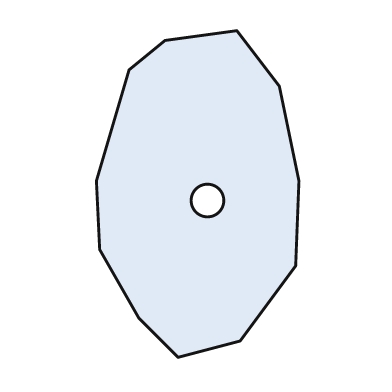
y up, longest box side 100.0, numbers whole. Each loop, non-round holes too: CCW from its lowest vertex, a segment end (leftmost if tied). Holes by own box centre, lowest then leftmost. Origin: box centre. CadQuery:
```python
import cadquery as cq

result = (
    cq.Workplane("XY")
    .moveTo(-6.0, -50.0)
    .lineTo(13.0, -45.0)
    .lineTo(30.0, -22.0)
    .lineTo(31.0, 4.0)
    .lineTo(25.0, 33.0)
    .lineTo(12.0, 50.0)
    .lineTo(-10.0, 47.0)
    .lineTo(-21.0, 38.0)
    .lineTo(-31.0, 4.0)
    .lineTo(-30.0, -17.0)
    .lineTo(-18.0, -38.0)
    .close()
    .moveTo(3.0, -2.0)
    .circle(5.0)
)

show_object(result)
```